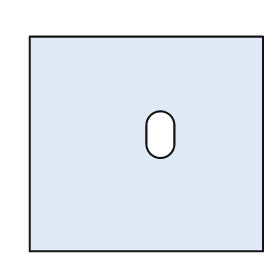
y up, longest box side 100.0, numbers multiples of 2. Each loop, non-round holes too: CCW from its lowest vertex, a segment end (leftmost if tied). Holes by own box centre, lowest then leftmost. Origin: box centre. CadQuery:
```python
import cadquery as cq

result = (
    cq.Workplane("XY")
    .moveTo(-50.0, -46.0)
    .lineTo(50.0, -46.0)
    .lineTo(50.0, 46.0)
    .lineTo(-50.0, 46.0)
    .close()
    .moveTo(0.0, 0.0)
    .threePointArc((6.0, -6.0), (12.0, 0.0))
    .lineTo(12.0, 8.0)
    .threePointArc((6.0, 14.0), (0.0, 8.0))
    .close()
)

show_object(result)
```